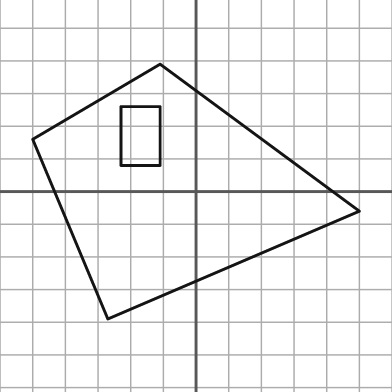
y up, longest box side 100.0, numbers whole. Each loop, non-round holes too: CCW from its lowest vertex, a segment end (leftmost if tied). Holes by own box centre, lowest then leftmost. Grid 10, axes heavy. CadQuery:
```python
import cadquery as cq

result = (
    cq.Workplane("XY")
    .moveTo(-27.0, -39.0)
    .lineTo(50.0, -6.0)
    .lineTo(-11.0, 39.0)
    .lineTo(-50.0, 16.0)
    .close()
    .moveTo(-23.0, 8.0)
    .lineTo(-11.0, 8.0)
    .lineTo(-11.0, 26.0)
    .lineTo(-23.0, 26.0)
    .close()
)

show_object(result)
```